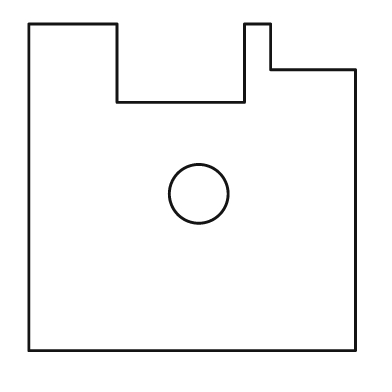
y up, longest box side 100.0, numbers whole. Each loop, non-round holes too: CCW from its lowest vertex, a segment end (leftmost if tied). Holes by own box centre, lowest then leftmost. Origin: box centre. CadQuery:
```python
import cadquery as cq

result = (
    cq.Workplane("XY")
    .moveTo(-50.0, -50.0)
    .lineTo(50.0, -50.0)
    .lineTo(50.0, 36.0)
    .lineTo(24.0, 36.0)
    .lineTo(24.0, 50.0)
    .lineTo(16.0, 50.0)
    .lineTo(16.0, 26.0)
    .lineTo(-23.0, 26.0)
    .lineTo(-23.0, 50.0)
    .lineTo(-50.0, 50.0)
    .close()
    .moveTo(2.0, -2.0)
    .circle(9.0)
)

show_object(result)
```